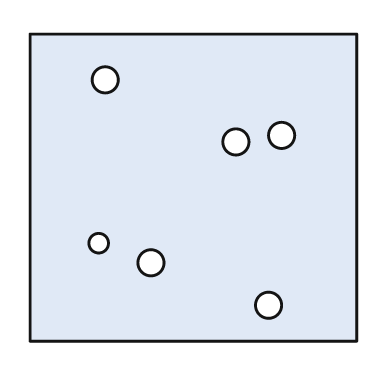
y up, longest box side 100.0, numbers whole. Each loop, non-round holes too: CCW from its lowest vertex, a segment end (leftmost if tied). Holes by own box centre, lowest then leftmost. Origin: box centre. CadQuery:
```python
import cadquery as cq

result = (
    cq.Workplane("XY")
    .moveTo(-50.0, -47.0)
    .lineTo(50.0, -47.0)
    .lineTo(50.0, 47.0)
    .lineTo(-50.0, 47.0)
    .close()
    .moveTo(23.0, -36.0)
    .circle(4.0)
    .moveTo(-13.0, -23.0)
    .circle(4.0)
    .moveTo(-29.0, -17.0)
    .circle(3.0)
    .moveTo(13.0, 14.0)
    .circle(4.0)
    .moveTo(27.0, 16.0)
    .circle(4.0)
    .moveTo(-27.0, 33.0)
    .circle(4.0)
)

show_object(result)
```